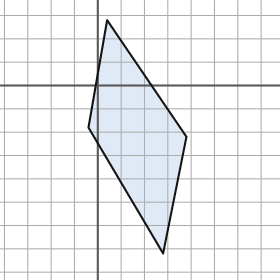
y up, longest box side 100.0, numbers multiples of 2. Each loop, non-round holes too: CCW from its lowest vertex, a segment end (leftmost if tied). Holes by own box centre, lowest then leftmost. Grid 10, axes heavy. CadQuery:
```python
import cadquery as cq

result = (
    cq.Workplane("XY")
    .moveTo(28.0, -72.0)
    .lineTo(38.0, -22.0)
    .lineTo(4.0, 28.0)
    .lineTo(-4.0, -18.0)
    .close()
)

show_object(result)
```